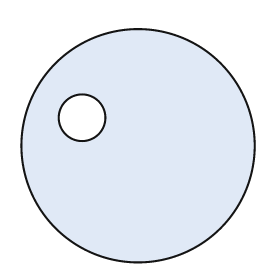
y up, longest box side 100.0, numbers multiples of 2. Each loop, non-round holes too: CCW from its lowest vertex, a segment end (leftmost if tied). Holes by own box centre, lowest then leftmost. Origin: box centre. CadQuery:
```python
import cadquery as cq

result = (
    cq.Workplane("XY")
    .moveTo(0.0, 0.0)
    .circle(50.0)
    .moveTo(-24.0, 12.0)
    .circle(10.0)
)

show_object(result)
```